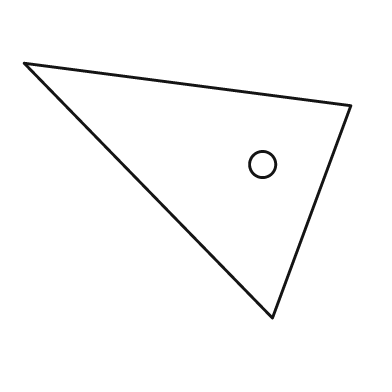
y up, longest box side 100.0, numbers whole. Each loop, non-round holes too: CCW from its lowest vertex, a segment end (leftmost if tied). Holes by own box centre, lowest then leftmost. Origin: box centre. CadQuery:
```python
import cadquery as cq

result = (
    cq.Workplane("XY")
    .moveTo(26.0, -39.0)
    .lineTo(50.0, 26.0)
    .lineTo(-50.0, 39.0)
    .close()
    .moveTo(23.0, 8.0)
    .circle(4.0)
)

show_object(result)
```